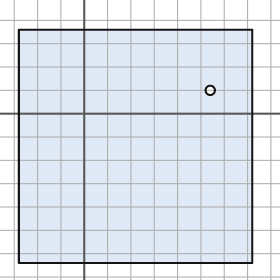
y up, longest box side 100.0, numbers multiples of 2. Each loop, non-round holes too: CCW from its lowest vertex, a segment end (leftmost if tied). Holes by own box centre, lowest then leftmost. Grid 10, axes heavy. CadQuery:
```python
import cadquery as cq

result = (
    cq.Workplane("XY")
    .moveTo(-28.0, -64.0)
    .lineTo(72.0, -64.0)
    .lineTo(72.0, 36.0)
    .lineTo(-28.0, 36.0)
    .close()
    .moveTo(54.0, 10.0)
    .circle(2.0)
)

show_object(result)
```